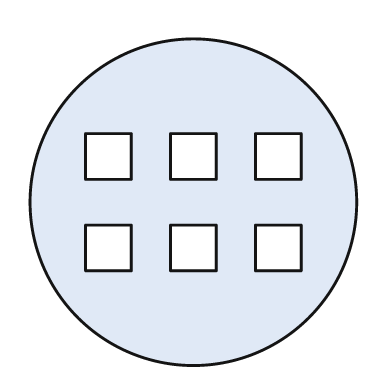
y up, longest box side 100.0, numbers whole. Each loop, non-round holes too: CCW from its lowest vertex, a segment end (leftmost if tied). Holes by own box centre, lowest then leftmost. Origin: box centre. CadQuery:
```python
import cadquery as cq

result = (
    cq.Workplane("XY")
    .moveTo(0.0, 0.0)
    .circle(50.0)
    .moveTo(-33.0, -21.0)
    .lineTo(-19.0, -21.0)
    .lineTo(-19.0, -7.0)
    .lineTo(-33.0, -7.0)
    .close()
    .moveTo(-7.0, -21.0)
    .lineTo(7.0, -21.0)
    .lineTo(7.0, -7.0)
    .lineTo(-7.0, -7.0)
    .close()
    .moveTo(19.0, -21.0)
    .lineTo(33.0, -21.0)
    .lineTo(33.0, -7.0)
    .lineTo(19.0, -7.0)
    .close()
    .moveTo(-33.0, 7.0)
    .lineTo(-19.0, 7.0)
    .lineTo(-19.0, 21.0)
    .lineTo(-33.0, 21.0)
    .close()
    .moveTo(-7.0, 7.0)
    .lineTo(7.0, 7.0)
    .lineTo(7.0, 21.0)
    .lineTo(-7.0, 21.0)
    .close()
    .moveTo(19.0, 7.0)
    .lineTo(33.0, 7.0)
    .lineTo(33.0, 21.0)
    .lineTo(19.0, 21.0)
    .close()
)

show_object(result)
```